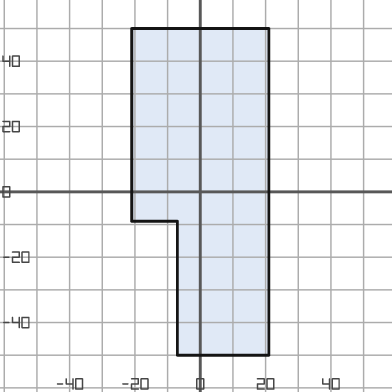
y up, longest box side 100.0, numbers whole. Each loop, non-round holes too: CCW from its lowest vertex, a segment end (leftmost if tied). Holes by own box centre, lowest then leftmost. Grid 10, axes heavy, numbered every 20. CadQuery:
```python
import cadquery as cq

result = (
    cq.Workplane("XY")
    .moveTo(-7.0, -50.0)
    .lineTo(21.0, -50.0)
    .lineTo(21.0, 50.0)
    .lineTo(-21.0, 50.0)
    .lineTo(-21.0, -9.0)
    .lineTo(-7.0, -9.0)
    .close()
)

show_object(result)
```